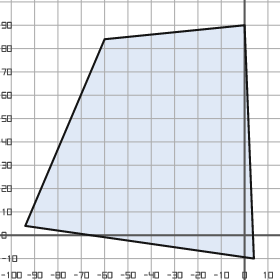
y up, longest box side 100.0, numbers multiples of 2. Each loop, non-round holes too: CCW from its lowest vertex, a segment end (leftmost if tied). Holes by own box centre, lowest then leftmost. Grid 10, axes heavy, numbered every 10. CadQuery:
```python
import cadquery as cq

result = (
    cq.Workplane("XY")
    .moveTo(4.0, -10.0)
    .lineTo(0.0, 90.0)
    .lineTo(-60.0, 84.0)
    .lineTo(-94.0, 4.0)
    .close()
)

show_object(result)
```